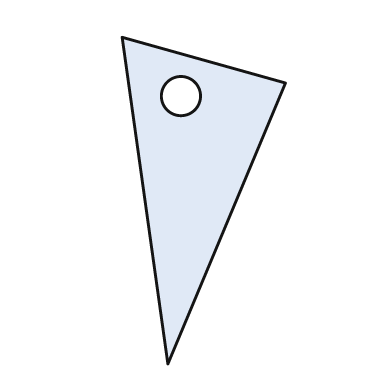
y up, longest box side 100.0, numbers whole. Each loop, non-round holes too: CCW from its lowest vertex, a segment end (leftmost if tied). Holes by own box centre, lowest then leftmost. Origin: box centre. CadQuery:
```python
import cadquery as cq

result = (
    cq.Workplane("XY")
    .moveTo(-11.0, -50.0)
    .lineTo(25.0, 36.0)
    .lineTo(-25.0, 50.0)
    .close()
    .moveTo(-7.0, 32.0)
    .circle(6.0)
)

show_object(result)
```